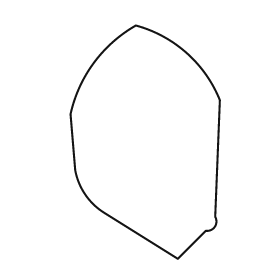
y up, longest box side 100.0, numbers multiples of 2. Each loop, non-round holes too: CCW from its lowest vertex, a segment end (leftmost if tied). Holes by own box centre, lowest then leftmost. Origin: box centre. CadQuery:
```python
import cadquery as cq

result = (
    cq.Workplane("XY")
    .moveTo(14.0, -50.0)
    .lineTo(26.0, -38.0)
    .threePointArc((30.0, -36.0), (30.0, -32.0))
    .lineTo(32.0, 18.0)
    .threePointArc((18.0, 38.0), (-4.0, 50.0))
    .threePointArc((-22.0, 34.0), (-32.0, 12.0))
    .lineTo(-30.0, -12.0)
    .threePointArc((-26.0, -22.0), (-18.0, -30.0))
    .close()
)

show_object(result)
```